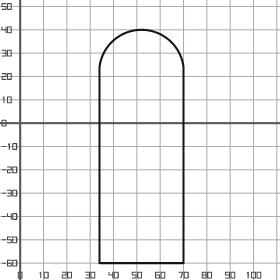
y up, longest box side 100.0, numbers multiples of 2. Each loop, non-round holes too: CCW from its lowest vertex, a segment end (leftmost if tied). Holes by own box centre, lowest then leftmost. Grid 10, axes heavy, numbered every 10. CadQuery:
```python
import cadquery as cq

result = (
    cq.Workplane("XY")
    .moveTo(34.0, -60.0)
    .lineTo(70.0, -60.0)
    .lineTo(70.0, 24.0)
    .threePointArc((52.0, 40.0), (34.0, 24.0))
    .close()
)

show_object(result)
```